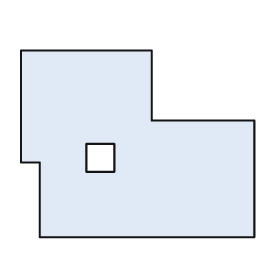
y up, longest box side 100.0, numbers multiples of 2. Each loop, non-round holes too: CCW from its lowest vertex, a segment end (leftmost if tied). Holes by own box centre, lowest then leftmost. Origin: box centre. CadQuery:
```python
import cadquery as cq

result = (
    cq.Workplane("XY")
    .moveTo(-42.0, -40.0)
    .lineTo(50.0, -40.0)
    .lineTo(50.0, 10.0)
    .lineTo(6.0, 10.0)
    .lineTo(6.0, 40.0)
    .lineTo(-50.0, 40.0)
    .lineTo(-50.0, -8.0)
    .lineTo(-42.0, -8.0)
    .close()
    .moveTo(-22.0, -12.0)
    .lineTo(-10.0, -12.0)
    .lineTo(-10.0, 0.0)
    .lineTo(-22.0, 0.0)
    .close()
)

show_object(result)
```